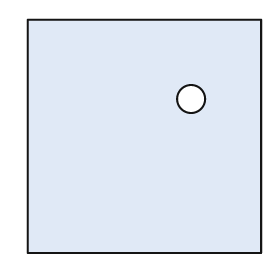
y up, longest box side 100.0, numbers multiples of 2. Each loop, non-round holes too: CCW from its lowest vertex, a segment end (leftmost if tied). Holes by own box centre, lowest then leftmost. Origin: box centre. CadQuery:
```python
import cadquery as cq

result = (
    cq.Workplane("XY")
    .moveTo(-50.0, -50.0)
    .lineTo(50.0, -50.0)
    .lineTo(50.0, 50.0)
    .lineTo(-50.0, 50.0)
    .close()
    .moveTo(20.0, 16.0)
    .circle(6.0)
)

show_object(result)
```